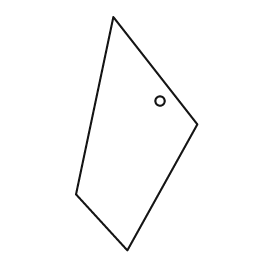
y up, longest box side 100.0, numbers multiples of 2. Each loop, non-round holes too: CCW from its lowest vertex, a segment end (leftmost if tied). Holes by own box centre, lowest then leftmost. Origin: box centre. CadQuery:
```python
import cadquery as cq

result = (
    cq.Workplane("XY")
    .moveTo(-4.0, -50.0)
    .lineTo(26.0, 4.0)
    .lineTo(-10.0, 50.0)
    .lineTo(-26.0, -26.0)
    .close()
    .moveTo(10.0, 14.0)
    .circle(2.0)
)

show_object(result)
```